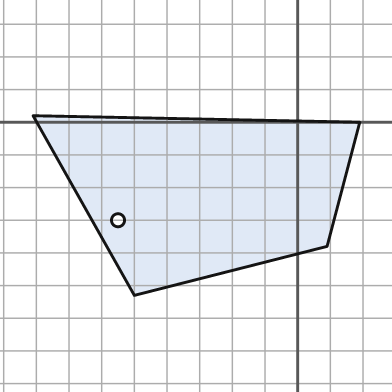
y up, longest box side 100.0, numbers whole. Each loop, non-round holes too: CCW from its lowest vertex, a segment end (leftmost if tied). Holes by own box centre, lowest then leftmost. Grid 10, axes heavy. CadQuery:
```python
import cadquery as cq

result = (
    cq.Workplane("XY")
    .moveTo(-50.0, -53.0)
    .lineTo(9.0, -38.0)
    .lineTo(19.0, 0.0)
    .lineTo(-81.0, 2.0)
    .close()
    .moveTo(-55.0, -30.0)
    .circle(2.0)
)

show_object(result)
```